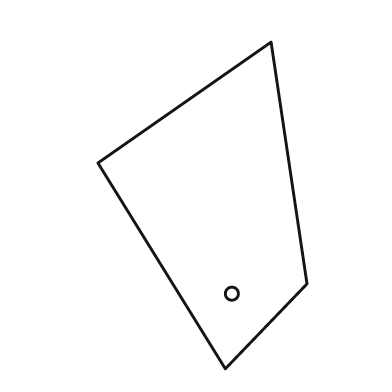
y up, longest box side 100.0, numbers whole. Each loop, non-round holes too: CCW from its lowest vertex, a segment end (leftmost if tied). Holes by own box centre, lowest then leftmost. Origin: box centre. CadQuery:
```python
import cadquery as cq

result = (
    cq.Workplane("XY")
    .moveTo(7.0, -50.0)
    .lineTo(32.0, -24.0)
    .lineTo(21.0, 50.0)
    .lineTo(-32.0, 13.0)
    .close()
    .moveTo(9.0, -27.0)
    .circle(2.0)
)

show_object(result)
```